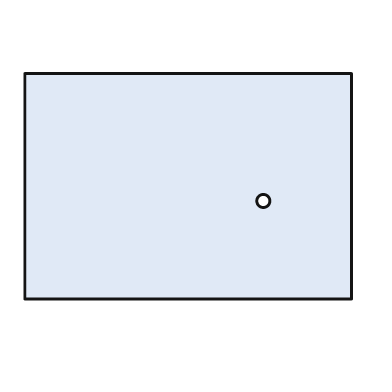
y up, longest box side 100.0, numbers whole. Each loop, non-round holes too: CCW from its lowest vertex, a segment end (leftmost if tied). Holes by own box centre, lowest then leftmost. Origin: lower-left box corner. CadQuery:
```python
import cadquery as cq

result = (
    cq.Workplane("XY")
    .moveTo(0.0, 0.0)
    .lineTo(100.0, 0.0)
    .lineTo(100.0, 69.0)
    .lineTo(0.0, 69.0)
    .close()
    .moveTo(73.0, 30.0)
    .circle(2.0)
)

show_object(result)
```